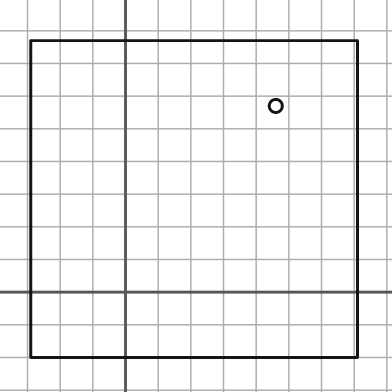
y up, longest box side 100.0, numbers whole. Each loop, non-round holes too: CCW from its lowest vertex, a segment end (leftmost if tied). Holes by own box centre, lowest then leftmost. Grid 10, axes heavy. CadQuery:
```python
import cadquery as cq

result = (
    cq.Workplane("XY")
    .moveTo(-29.0, -20.0)
    .lineTo(71.0, -20.0)
    .lineTo(71.0, 77.0)
    .lineTo(-29.0, 77.0)
    .close()
    .moveTo(46.0, 57.0)
    .circle(2.0)
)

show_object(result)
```